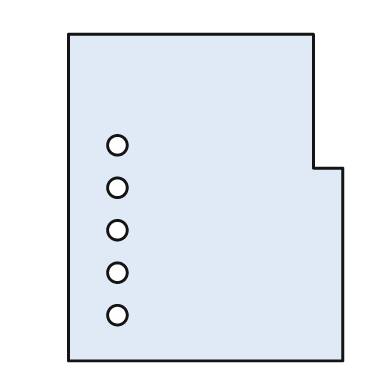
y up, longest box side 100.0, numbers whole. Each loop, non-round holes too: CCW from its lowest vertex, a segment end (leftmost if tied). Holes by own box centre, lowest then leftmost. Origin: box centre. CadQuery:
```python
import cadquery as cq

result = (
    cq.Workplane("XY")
    .moveTo(-42.0, -50.0)
    .lineTo(42.0, -50.0)
    .lineTo(42.0, 9.0)
    .lineTo(33.0, 9.0)
    .lineTo(33.0, 50.0)
    .lineTo(-42.0, 50.0)
    .close()
    .moveTo(-27.0, -36.0)
    .circle(3.0)
    .moveTo(-27.0, -23.0)
    .circle(3.0)
    .moveTo(-27.0, -10.0)
    .circle(3.0)
    .moveTo(-27.0, 3.0)
    .circle(3.0)
    .moveTo(-27.0, 16.0)
    .circle(3.0)
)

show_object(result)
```